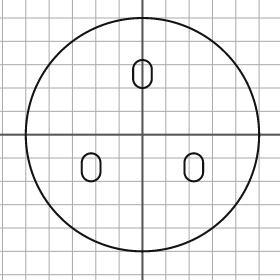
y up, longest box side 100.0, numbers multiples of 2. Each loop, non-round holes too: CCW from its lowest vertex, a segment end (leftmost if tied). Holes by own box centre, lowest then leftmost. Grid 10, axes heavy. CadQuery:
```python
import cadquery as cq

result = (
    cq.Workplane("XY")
    .moveTo(0.0, 0.0)
    .circle(50.0)
    .moveTo(-26.0, -16.0)
    .threePointArc((-22.0, -20.0), (-18.0, -16.0))
    .lineTo(-18.0, -12.0)
    .threePointArc((-22.0, -8.0), (-26.0, -12.0))
    .close()
    .moveTo(18.0, -16.0)
    .threePointArc((22.0, -20.0), (26.0, -16.0))
    .lineTo(26.0, -12.0)
    .threePointArc((22.0, -8.0), (18.0, -12.0))
    .close()
    .moveTo(-4.0, 24.0)
    .threePointArc((0.0, 20.0), (4.0, 24.0))
    .lineTo(4.0, 28.0)
    .threePointArc((0.0, 32.0), (-4.0, 28.0))
    .close()
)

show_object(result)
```